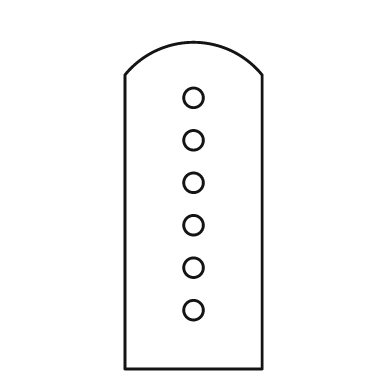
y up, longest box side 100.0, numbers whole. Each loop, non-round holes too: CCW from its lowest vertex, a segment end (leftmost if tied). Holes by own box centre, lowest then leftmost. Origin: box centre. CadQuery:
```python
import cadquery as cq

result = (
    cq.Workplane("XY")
    .moveTo(-21.0, -50.0)
    .lineTo(21.0, -50.0)
    .lineTo(21.0, 40.0)
    .threePointArc((0.0, 50.0), (-21.0, 40.0))
    .close()
    .moveTo(0.0, -32.0)
    .circle(3.0)
    .moveTo(0.0, -19.0)
    .circle(3.0)
    .moveTo(0.0, -6.0)
    .circle(3.0)
    .moveTo(0.0, 7.0)
    .circle(3.0)
    .moveTo(0.0, 20.0)
    .circle(3.0)
    .moveTo(0.0, 33.0)
    .circle(3.0)
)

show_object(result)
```